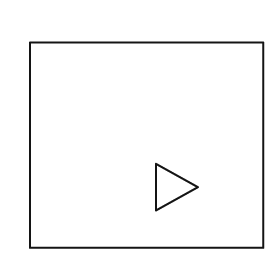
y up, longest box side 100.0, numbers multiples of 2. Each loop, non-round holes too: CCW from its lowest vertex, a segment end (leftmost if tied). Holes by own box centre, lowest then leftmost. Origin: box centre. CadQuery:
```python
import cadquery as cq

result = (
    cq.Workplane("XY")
    .moveTo(-50.0, -44.0)
    .lineTo(50.0, -44.0)
    .lineTo(50.0, 44.0)
    .lineTo(-50.0, 44.0)
    .close()
    .moveTo(4.0, -28.0)
    .lineTo(22.0, -18.0)
    .lineTo(4.0, -8.0)
    .close()
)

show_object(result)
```